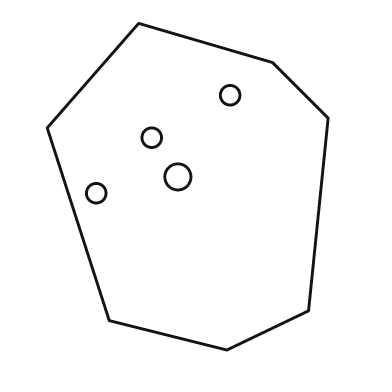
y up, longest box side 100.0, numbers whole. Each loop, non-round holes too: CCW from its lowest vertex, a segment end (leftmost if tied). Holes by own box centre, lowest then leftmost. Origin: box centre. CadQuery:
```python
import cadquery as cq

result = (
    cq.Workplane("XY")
    .moveTo(12.0, -50.0)
    .lineTo(37.0, -38.0)
    .lineTo(43.0, 21.0)
    .lineTo(26.0, 38.0)
    .lineTo(-15.0, 50.0)
    .lineTo(-43.0, 18.0)
    .lineTo(-24.0, -41.0)
    .close()
    .moveTo(-28.0, -2.0)
    .circle(3.0)
    .moveTo(-3.0, 3.0)
    .circle(4.0)
    .moveTo(-11.0, 15.0)
    .circle(3.0)
    .moveTo(13.0, 28.0)
    .circle(3.0)
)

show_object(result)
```